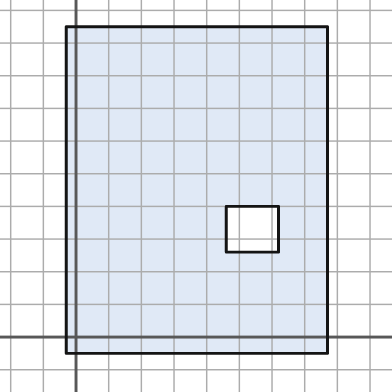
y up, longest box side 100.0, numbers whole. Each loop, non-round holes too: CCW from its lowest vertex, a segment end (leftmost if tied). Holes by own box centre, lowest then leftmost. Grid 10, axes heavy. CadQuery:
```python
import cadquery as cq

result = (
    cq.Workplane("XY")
    .moveTo(-3.0, -5.0)
    .lineTo(77.0, -5.0)
    .lineTo(77.0, 95.0)
    .lineTo(-3.0, 95.0)
    .close()
    .moveTo(46.0, 26.0)
    .lineTo(62.0, 26.0)
    .lineTo(62.0, 40.0)
    .lineTo(46.0, 40.0)
    .close()
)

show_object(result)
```